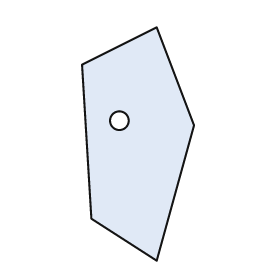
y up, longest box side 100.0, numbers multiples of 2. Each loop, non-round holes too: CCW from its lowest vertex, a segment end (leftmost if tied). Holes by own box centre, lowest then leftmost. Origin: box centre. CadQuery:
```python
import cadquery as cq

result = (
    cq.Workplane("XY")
    .moveTo(8.0, -50.0)
    .lineTo(24.0, 8.0)
    .lineTo(8.0, 50.0)
    .lineTo(-24.0, 34.0)
    .lineTo(-20.0, -32.0)
    .close()
    .moveTo(-8.0, 10.0)
    .circle(4.0)
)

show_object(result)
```